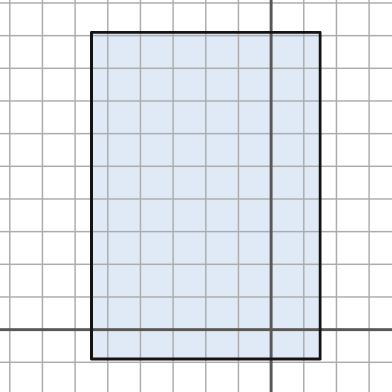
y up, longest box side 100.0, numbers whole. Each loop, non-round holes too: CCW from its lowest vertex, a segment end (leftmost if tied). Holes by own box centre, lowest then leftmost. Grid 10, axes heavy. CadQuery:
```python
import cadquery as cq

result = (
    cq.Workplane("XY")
    .moveTo(-55.0, -9.0)
    .lineTo(15.0, -9.0)
    .lineTo(15.0, 91.0)
    .lineTo(-55.0, 91.0)
    .close()
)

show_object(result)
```